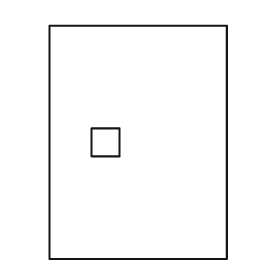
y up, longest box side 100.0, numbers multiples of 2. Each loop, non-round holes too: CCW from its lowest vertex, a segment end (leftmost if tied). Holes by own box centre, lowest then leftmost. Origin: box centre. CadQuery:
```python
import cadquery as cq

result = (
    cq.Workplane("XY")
    .moveTo(-38.0, -50.0)
    .lineTo(38.0, -50.0)
    .lineTo(38.0, 50.0)
    .lineTo(-38.0, 50.0)
    .close()
    .moveTo(-20.0, -6.0)
    .lineTo(-8.0, -6.0)
    .lineTo(-8.0, 6.0)
    .lineTo(-20.0, 6.0)
    .close()
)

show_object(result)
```